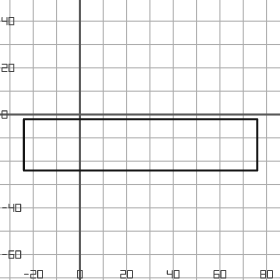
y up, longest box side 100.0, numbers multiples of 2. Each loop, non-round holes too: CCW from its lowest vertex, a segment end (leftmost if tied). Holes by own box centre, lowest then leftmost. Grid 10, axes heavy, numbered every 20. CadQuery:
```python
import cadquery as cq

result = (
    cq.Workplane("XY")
    .moveTo(-24.0, -24.0)
    .lineTo(76.0, -24.0)
    .lineTo(76.0, -2.0)
    .lineTo(-24.0, -2.0)
    .close()
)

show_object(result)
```